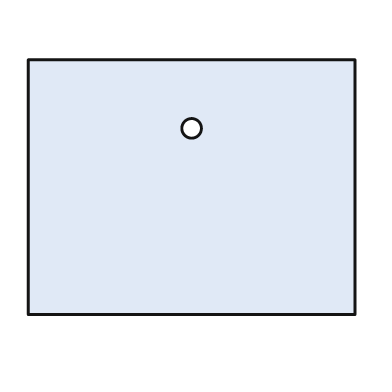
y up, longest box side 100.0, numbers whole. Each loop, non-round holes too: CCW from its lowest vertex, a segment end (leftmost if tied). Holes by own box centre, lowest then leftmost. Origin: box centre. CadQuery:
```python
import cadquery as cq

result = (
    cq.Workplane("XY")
    .moveTo(-50.0, -39.0)
    .lineTo(50.0, -39.0)
    .lineTo(50.0, 39.0)
    .lineTo(-50.0, 39.0)
    .close()
    .moveTo(0.0, 18.0)
    .circle(3.0)
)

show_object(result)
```